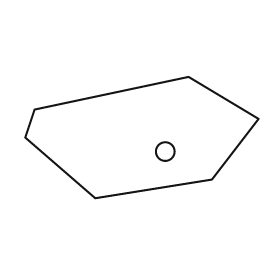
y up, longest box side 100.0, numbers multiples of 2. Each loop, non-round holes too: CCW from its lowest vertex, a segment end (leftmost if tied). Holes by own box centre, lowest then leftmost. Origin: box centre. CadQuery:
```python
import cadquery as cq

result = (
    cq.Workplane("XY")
    .moveTo(-20.0, -26.0)
    .lineTo(30.0, -18.0)
    .lineTo(50.0, 8.0)
    .lineTo(20.0, 26.0)
    .lineTo(-46.0, 12.0)
    .lineTo(-50.0, 0.0)
    .close()
    .moveTo(10.0, -6.0)
    .circle(4.0)
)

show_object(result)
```